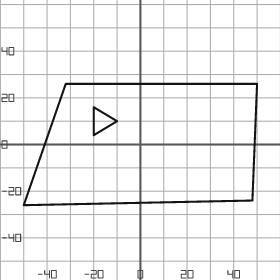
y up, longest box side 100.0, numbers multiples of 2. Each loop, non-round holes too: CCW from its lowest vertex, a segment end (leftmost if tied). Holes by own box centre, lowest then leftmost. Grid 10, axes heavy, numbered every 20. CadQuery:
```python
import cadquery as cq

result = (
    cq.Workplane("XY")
    .moveTo(-50.0, -26.0)
    .lineTo(48.0, -24.0)
    .lineTo(50.0, 26.0)
    .lineTo(-32.0, 26.0)
    .close()
    .moveTo(-20.0, 4.0)
    .lineTo(-10.0, 10.0)
    .lineTo(-20.0, 16.0)
    .close()
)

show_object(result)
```